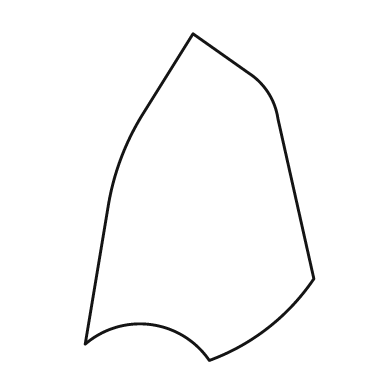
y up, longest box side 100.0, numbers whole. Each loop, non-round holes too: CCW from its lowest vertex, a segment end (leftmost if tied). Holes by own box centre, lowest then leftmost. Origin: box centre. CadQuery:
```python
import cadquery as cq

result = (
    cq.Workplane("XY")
    .moveTo(3.0, -50.0)
    .threePointArc((21.0, -40.0), (35.0, -25.0))
    .lineTo(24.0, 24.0)
    .threePointArc((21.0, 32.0), (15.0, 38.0))
    .lineTo(-2.0, 50.0)
    .lineTo(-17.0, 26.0)
    .threePointArc((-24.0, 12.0), (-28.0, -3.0))
    .lineTo(-35.0, -45.0)
    .threePointArc((-15.0, -39.0), (3.0, -50.0))
    .close()
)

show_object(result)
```